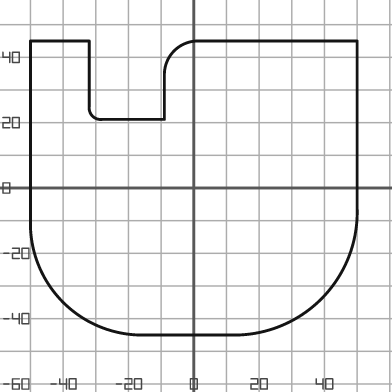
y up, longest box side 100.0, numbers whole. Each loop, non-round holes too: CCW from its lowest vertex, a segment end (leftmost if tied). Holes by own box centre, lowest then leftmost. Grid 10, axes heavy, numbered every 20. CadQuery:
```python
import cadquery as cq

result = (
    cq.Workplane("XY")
    .moveTo(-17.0, -45.0)
    .lineTo(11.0, -45.0)
    .threePointArc((39.0, -34.0), (50.0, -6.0))
    .lineTo(50.0, 45.0)
    .lineTo(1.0, 45.0)
    .threePointArc((-6.0, 42.0), (-9.0, 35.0))
    .lineTo(-9.0, 21.0)
    .lineTo(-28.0, 21.0)
    .threePointArc((-31.0, 22.0), (-32.0, 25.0))
    .lineTo(-32.0, 45.0)
    .lineTo(-50.0, 45.0)
    .lineTo(-50.0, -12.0)
    .threePointArc((-40.0, -35.0), (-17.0, -45.0))
    .close()
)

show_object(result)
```